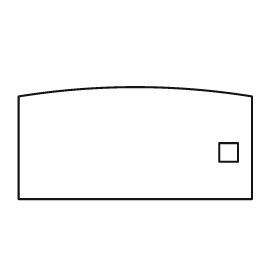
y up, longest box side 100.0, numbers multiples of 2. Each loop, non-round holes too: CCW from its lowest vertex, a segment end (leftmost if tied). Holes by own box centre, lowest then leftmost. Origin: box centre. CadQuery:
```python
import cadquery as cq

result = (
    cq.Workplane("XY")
    .moveTo(-50.0, -24.0)
    .lineTo(50.0, -24.0)
    .lineTo(50.0, 20.0)
    .threePointArc((0.0, 24.0), (-50.0, 20.0))
    .close()
    .moveTo(36.0, -8.0)
    .lineTo(44.0, -8.0)
    .lineTo(44.0, 0.0)
    .lineTo(36.0, 0.0)
    .close()
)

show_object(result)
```